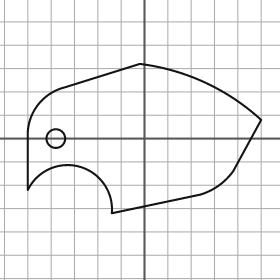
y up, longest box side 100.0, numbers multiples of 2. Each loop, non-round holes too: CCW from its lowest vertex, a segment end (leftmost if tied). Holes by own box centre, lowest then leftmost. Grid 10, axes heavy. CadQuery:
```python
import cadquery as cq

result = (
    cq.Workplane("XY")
    .moveTo(-14.0, -32.0)
    .lineTo(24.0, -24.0)
    .threePointArc((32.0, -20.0), (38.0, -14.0))
    .lineTo(50.0, 8.0)
    .threePointArc((26.0, 24.0), (-2.0, 32.0))
    .lineTo(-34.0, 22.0)
    .threePointArc((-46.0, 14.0), (-50.0, 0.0))
    .lineTo(-50.0, -22.0)
    .threePointArc((-28.0, -12.0), (-14.0, -32.0))
    .close()
    .moveTo(-38.0, 0.0)
    .circle(4.0)
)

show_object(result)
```